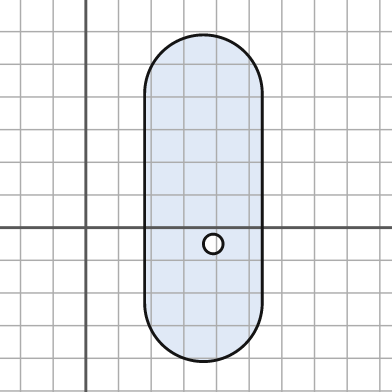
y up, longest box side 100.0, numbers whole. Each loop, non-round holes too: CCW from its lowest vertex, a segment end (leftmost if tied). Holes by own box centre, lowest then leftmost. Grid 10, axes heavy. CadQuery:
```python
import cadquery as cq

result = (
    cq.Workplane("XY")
    .moveTo(18.0, -23.0)
    .threePointArc((36.0, -41.0), (54.0, -23.0))
    .lineTo(54.0, 41.0)
    .threePointArc((36.0, 59.0), (18.0, 41.0))
    .close()
    .moveTo(39.0, -5.0)
    .circle(3.0)
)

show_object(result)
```